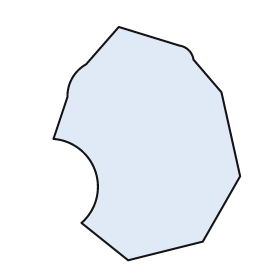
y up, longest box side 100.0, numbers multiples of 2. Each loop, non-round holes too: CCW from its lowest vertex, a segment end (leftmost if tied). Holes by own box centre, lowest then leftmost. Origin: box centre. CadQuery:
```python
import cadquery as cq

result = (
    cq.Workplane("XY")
    .moveTo(-8.0, -50.0)
    .lineTo(24.0, -42.0)
    .lineTo(40.0, -14.0)
    .lineTo(32.0, 22.0)
    .lineTo(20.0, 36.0)
    .threePointArc((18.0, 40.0), (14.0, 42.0))
    .lineTo(-12.0, 50.0)
    .lineTo(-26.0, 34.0)
    .threePointArc((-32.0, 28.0), (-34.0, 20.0))
    .lineTo(-40.0, 2.0)
    .threePointArc((-22.0, -12.0), (-28.0, -34.0))
    .close()
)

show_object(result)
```